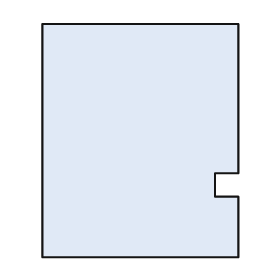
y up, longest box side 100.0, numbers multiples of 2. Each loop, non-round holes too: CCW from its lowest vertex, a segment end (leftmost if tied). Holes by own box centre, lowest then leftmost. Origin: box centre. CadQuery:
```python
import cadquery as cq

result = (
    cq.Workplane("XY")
    .moveTo(-42.0, -50.0)
    .lineTo(42.0, -50.0)
    .lineTo(42.0, -24.0)
    .lineTo(32.0, -24.0)
    .lineTo(32.0, -14.0)
    .lineTo(42.0, -14.0)
    .lineTo(42.0, 50.0)
    .lineTo(-42.0, 50.0)
    .close()
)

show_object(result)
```